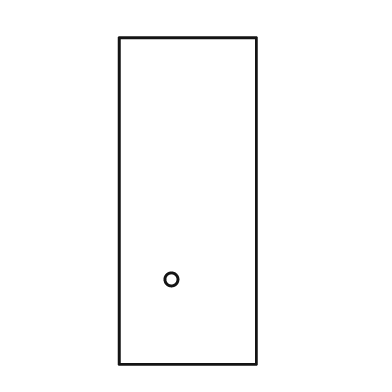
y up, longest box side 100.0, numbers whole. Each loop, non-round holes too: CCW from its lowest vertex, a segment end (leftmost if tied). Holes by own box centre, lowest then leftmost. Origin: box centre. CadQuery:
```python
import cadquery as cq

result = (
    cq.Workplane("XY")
    .moveTo(-21.0, -50.0)
    .lineTo(21.0, -50.0)
    .lineTo(21.0, 50.0)
    .lineTo(-21.0, 50.0)
    .close()
    .moveTo(-5.0, -24.0)
    .circle(2.0)
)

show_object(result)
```